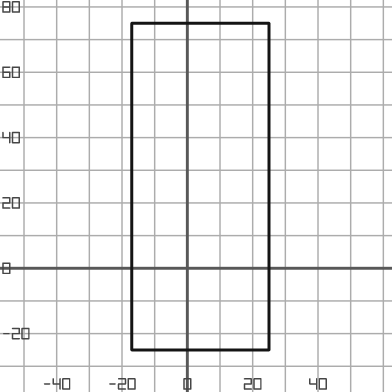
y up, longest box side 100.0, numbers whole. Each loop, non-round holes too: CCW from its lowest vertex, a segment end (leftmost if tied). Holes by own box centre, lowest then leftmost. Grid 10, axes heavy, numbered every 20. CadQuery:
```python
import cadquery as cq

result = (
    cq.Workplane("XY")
    .moveTo(-17.0, -25.0)
    .lineTo(25.0, -25.0)
    .lineTo(25.0, 75.0)
    .lineTo(-17.0, 75.0)
    .close()
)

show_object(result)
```